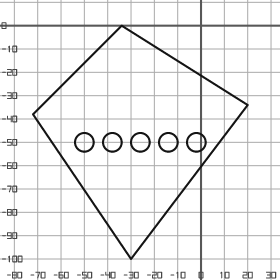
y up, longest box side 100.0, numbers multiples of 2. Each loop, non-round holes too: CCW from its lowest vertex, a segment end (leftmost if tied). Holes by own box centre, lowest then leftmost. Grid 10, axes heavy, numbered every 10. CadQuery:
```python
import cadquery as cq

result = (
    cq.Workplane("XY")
    .moveTo(-30.0, -100.0)
    .lineTo(20.0, -34.0)
    .lineTo(-34.0, 0.0)
    .lineTo(-72.0, -38.0)
    .close()
    .moveTo(-50.0, -50.0)
    .circle(4.0)
    .moveTo(-38.0, -50.0)
    .circle(4.0)
    .moveTo(-26.0, -50.0)
    .circle(4.0)
    .moveTo(-14.0, -50.0)
    .circle(4.0)
    .moveTo(-2.0, -50.0)
    .circle(4.0)
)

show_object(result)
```